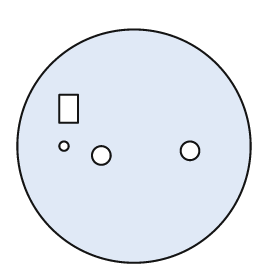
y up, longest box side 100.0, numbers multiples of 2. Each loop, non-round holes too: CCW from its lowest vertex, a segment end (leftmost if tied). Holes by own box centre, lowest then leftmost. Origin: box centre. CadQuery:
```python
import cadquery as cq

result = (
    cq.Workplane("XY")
    .moveTo(0.0, 0.0)
    .circle(50.0)
    .moveTo(-14.0, -4.0)
    .circle(4.0)
    .moveTo(24.0, -2.0)
    .circle(4.0)
    .moveTo(-30.0, 0.0)
    .circle(2.0)
    .moveTo(-32.0, 10.0)
    .lineTo(-24.0, 10.0)
    .lineTo(-24.0, 22.0)
    .lineTo(-32.0, 22.0)
    .close()
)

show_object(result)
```